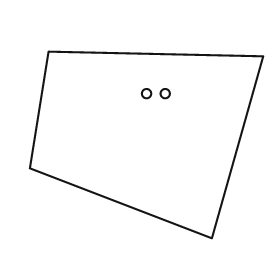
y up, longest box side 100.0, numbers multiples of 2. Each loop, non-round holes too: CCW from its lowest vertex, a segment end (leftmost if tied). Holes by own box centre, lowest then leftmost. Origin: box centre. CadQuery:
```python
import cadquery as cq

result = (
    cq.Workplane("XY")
    .moveTo(28.0, -40.0)
    .lineTo(50.0, 38.0)
    .lineTo(-42.0, 40.0)
    .lineTo(-50.0, -10.0)
    .close()
    .moveTo(0.0, 22.0)
    .circle(2.0)
    .moveTo(8.0, 22.0)
    .circle(2.0)
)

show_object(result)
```